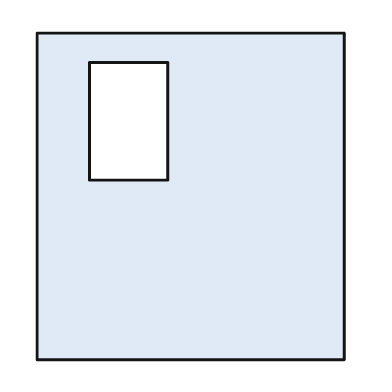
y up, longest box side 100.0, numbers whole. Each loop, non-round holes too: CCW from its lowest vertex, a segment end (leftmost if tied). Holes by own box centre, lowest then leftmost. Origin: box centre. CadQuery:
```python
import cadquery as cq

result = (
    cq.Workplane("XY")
    .moveTo(-47.0, -50.0)
    .lineTo(47.0, -50.0)
    .lineTo(47.0, 50.0)
    .lineTo(-47.0, 50.0)
    .close()
    .moveTo(-31.0, 5.0)
    .lineTo(-7.0, 5.0)
    .lineTo(-7.0, 41.0)
    .lineTo(-31.0, 41.0)
    .close()
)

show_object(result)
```